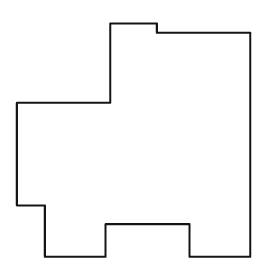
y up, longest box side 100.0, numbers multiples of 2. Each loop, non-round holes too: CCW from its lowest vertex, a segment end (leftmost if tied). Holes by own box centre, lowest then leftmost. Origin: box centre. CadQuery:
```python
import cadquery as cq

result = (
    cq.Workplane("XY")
    .moveTo(-38.0, -50.0)
    .lineTo(-12.0, -50.0)
    .lineTo(-12.0, -36.0)
    .lineTo(24.0, -36.0)
    .lineTo(24.0, -50.0)
    .lineTo(50.0, -50.0)
    .lineTo(50.0, 46.0)
    .lineTo(10.0, 46.0)
    .lineTo(10.0, 50.0)
    .lineTo(-10.0, 50.0)
    .lineTo(-10.0, 16.0)
    .lineTo(-50.0, 16.0)
    .lineTo(-50.0, -28.0)
    .lineTo(-38.0, -28.0)
    .close()
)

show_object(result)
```